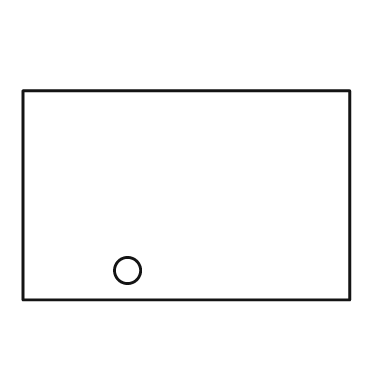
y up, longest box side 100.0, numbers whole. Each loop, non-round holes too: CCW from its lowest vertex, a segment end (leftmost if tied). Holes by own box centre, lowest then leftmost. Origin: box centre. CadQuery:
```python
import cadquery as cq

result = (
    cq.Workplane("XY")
    .moveTo(-50.0, -32.0)
    .lineTo(50.0, -32.0)
    .lineTo(50.0, 32.0)
    .lineTo(-50.0, 32.0)
    .close()
    .moveTo(-18.0, -23.0)
    .circle(4.0)
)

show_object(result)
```